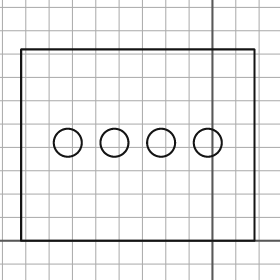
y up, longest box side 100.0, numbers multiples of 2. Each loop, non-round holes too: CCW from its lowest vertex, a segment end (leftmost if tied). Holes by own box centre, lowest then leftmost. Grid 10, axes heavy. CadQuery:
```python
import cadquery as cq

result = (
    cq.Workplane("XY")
    .moveTo(-82.0, 0.0)
    .lineTo(18.0, 0.0)
    .lineTo(18.0, 82.0)
    .lineTo(-82.0, 82.0)
    .close()
    .moveTo(-62.0, 42.0)
    .circle(6.0)
    .moveTo(-42.0, 42.0)
    .circle(6.0)
    .moveTo(-22.0, 42.0)
    .circle(6.0)
    .moveTo(-2.0, 42.0)
    .circle(6.0)
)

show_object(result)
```